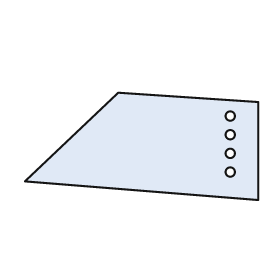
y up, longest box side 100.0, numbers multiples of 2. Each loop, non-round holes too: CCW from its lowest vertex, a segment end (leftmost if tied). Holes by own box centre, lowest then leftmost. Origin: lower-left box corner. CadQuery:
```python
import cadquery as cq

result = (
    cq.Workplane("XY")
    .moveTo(100.0, 0.0)
    .lineTo(100.0, 42.0)
    .lineTo(40.0, 46.0)
    .lineTo(0.0, 8.0)
    .close()
    .moveTo(88.0, 12.0)
    .circle(2.0)
    .moveTo(88.0, 20.0)
    .circle(2.0)
    .moveTo(88.0, 28.0)
    .circle(2.0)
    .moveTo(88.0, 36.0)
    .circle(2.0)
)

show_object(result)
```